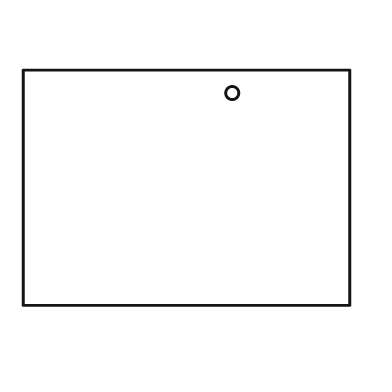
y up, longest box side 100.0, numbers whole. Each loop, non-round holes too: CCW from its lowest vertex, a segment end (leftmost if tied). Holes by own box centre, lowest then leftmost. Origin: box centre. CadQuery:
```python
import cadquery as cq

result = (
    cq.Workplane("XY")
    .moveTo(-50.0, -36.0)
    .lineTo(50.0, -36.0)
    .lineTo(50.0, 36.0)
    .lineTo(-50.0, 36.0)
    .close()
    .moveTo(14.0, 29.0)
    .circle(2.0)
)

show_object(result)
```